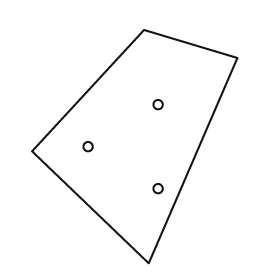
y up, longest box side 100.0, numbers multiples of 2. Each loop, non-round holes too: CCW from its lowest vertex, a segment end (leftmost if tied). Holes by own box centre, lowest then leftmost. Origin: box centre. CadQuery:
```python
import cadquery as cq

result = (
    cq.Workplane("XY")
    .moveTo(6.0, -50.0)
    .lineTo(44.0, 38.0)
    .lineTo(4.0, 50.0)
    .lineTo(-44.0, -2.0)
    .close()
    .moveTo(10.0, -18.0)
    .circle(2.0)
    .moveTo(-20.0, 0.0)
    .circle(2.0)
    .moveTo(10.0, 18.0)
    .circle(2.0)
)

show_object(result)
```